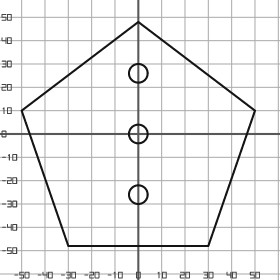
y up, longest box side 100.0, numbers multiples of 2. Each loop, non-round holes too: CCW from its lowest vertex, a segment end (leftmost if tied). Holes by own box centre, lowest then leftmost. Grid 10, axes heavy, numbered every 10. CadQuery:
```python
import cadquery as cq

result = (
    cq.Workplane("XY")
    .moveTo(-30.0, -48.0)
    .lineTo(30.0, -48.0)
    .lineTo(50.0, 10.0)
    .lineTo(0.0, 48.0)
    .lineTo(-50.0, 10.0)
    .close()
    .moveTo(0.0, -26.0)
    .circle(4.0)
    .moveTo(0.0, 0.0)
    .circle(4.0)
    .moveTo(0.0, 26.0)
    .circle(4.0)
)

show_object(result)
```